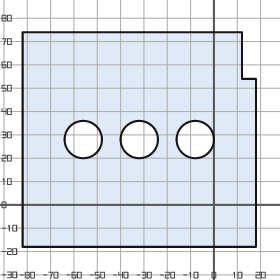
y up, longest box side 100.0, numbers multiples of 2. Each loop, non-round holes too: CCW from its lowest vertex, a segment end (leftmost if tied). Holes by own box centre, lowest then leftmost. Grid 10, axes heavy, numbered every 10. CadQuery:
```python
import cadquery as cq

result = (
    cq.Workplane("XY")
    .moveTo(-82.0, -18.0)
    .lineTo(18.0, -18.0)
    .lineTo(18.0, 54.0)
    .lineTo(12.0, 54.0)
    .lineTo(12.0, 74.0)
    .lineTo(-82.0, 74.0)
    .close()
    .moveTo(-56.0, 28.0)
    .circle(8.0)
    .moveTo(-32.0, 28.0)
    .circle(8.0)
    .moveTo(-8.0, 28.0)
    .circle(8.0)
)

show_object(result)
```